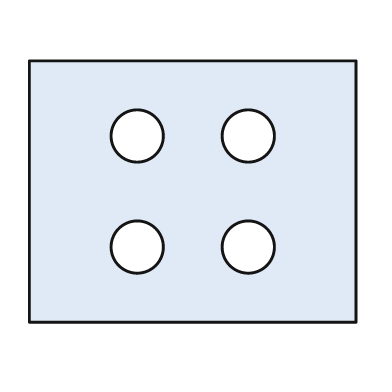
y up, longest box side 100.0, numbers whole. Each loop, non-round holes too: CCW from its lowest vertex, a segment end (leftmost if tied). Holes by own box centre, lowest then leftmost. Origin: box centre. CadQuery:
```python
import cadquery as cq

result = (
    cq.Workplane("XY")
    .moveTo(-50.0, -40.0)
    .lineTo(50.0, -40.0)
    .lineTo(50.0, 40.0)
    .lineTo(-50.0, 40.0)
    .close()
    .moveTo(-17.0, -17.0)
    .circle(8.0)
    .moveTo(17.0, -17.0)
    .circle(8.0)
    .moveTo(-17.0, 17.0)
    .circle(8.0)
    .moveTo(17.0, 17.0)
    .circle(8.0)
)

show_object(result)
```